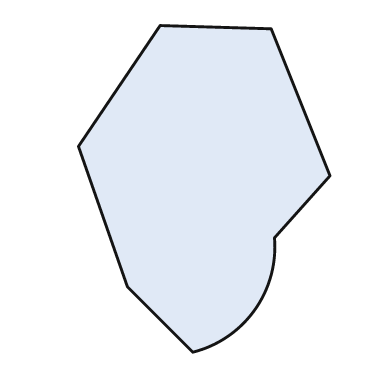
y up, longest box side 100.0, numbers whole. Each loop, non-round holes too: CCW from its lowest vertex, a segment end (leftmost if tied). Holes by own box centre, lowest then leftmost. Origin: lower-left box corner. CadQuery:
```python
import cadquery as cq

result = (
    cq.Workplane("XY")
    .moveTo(35.0, 0.0)
    .threePointArc((54.0, 13.0), (60.0, 35.0))
    .lineTo(77.0, 54.0)
    .lineTo(59.0, 99.0)
    .lineTo(25.0, 100.0)
    .lineTo(0.0, 63.0)
    .lineTo(15.0, 20.0)
    .close()
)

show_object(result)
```